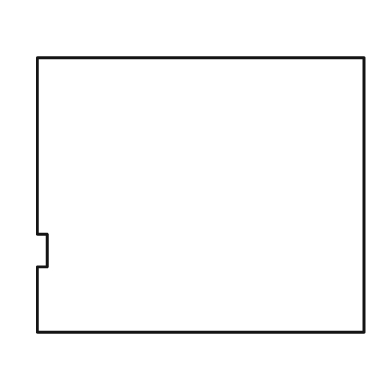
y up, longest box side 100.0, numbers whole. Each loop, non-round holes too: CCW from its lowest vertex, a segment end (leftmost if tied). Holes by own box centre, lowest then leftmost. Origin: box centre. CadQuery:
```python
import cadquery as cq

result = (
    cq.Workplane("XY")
    .moveTo(-50.0, -42.0)
    .lineTo(50.0, -42.0)
    .lineTo(50.0, 42.0)
    .lineTo(-50.0, 42.0)
    .lineTo(-50.0, -12.0)
    .lineTo(-47.0, -12.0)
    .lineTo(-47.0, -22.0)
    .lineTo(-50.0, -22.0)
    .close()
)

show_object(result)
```